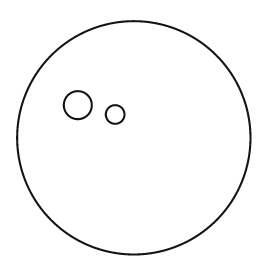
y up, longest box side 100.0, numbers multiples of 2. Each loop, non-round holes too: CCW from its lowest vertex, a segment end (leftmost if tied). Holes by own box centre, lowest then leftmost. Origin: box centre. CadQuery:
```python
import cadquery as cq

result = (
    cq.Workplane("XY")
    .moveTo(0.0, 0.0)
    .circle(50.0)
    .moveTo(-8.0, 10.0)
    .circle(4.0)
    .moveTo(-24.0, 14.0)
    .circle(6.0)
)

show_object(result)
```